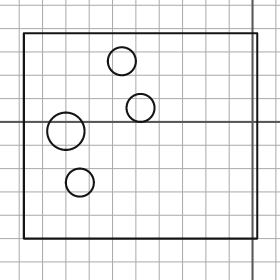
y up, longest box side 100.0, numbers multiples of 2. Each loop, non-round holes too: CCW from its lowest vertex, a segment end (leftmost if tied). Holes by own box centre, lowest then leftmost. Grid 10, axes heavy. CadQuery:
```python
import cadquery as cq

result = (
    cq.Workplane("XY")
    .moveTo(-98.0, -50.0)
    .lineTo(2.0, -50.0)
    .lineTo(2.0, 38.0)
    .lineTo(-98.0, 38.0)
    .close()
    .moveTo(-74.0, -26.0)
    .circle(6.0)
    .moveTo(-80.0, -4.0)
    .circle(8.0)
    .moveTo(-48.0, 6.0)
    .circle(6.0)
    .moveTo(-56.0, 26.0)
    .circle(6.0)
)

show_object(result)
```